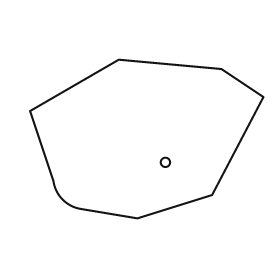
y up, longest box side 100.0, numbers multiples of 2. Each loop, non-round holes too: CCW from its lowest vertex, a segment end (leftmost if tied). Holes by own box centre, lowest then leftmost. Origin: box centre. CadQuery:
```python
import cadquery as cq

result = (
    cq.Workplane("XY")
    .moveTo(-4.0, -34.0)
    .lineTo(28.0, -24.0)
    .lineTo(50.0, 18.0)
    .lineTo(32.0, 30.0)
    .lineTo(-12.0, 34.0)
    .lineTo(-50.0, 12.0)
    .lineTo(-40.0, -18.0)
    .threePointArc((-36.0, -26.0), (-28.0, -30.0))
    .close()
    .moveTo(8.0, -10.0)
    .circle(2.0)
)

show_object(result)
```